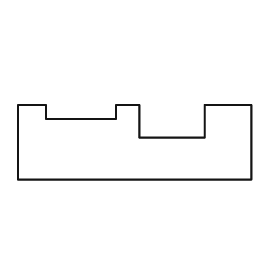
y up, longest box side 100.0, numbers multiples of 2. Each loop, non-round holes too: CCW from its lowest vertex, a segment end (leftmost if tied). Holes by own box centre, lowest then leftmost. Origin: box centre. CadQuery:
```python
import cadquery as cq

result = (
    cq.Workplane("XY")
    .moveTo(-50.0, -16.0)
    .lineTo(50.0, -16.0)
    .lineTo(50.0, 16.0)
    .lineTo(30.0, 16.0)
    .lineTo(30.0, 2.0)
    .lineTo(2.0, 2.0)
    .lineTo(2.0, 16.0)
    .lineTo(-8.0, 16.0)
    .lineTo(-8.0, 10.0)
    .lineTo(-38.0, 10.0)
    .lineTo(-38.0, 16.0)
    .lineTo(-50.0, 16.0)
    .close()
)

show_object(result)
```